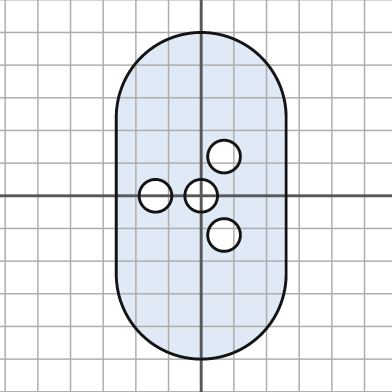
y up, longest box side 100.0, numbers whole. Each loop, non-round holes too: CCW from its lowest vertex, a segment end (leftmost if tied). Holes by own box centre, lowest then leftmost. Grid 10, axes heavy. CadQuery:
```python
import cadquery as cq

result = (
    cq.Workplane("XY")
    .moveTo(-26.0, -24.0)
    .threePointArc((0.0, -50.0), (26.0, -24.0))
    .lineTo(26.0, 24.0)
    .threePointArc((0.0, 50.0), (-26.0, 24.0))
    .close()
    .moveTo(7.0, -12.0)
    .circle(5.0)
    .moveTo(-14.0, 0.0)
    .circle(5.0)
    .moveTo(0.0, 0.0)
    .circle(5.0)
    .moveTo(7.0, 12.0)
    .circle(5.0)
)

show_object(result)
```